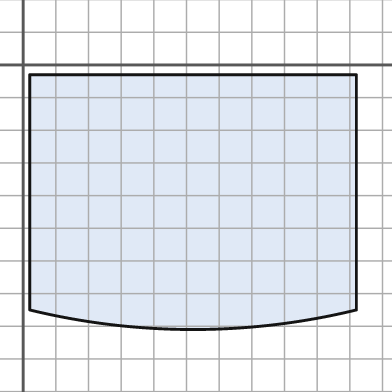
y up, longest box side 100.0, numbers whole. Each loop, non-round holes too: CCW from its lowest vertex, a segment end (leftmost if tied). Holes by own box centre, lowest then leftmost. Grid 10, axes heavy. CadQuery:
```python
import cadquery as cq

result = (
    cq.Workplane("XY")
    .moveTo(2.0, -75.0)
    .threePointArc((52.0, -81.0), (102.0, -75.0))
    .lineTo(102.0, -3.0)
    .lineTo(2.0, -3.0)
    .close()
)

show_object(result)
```